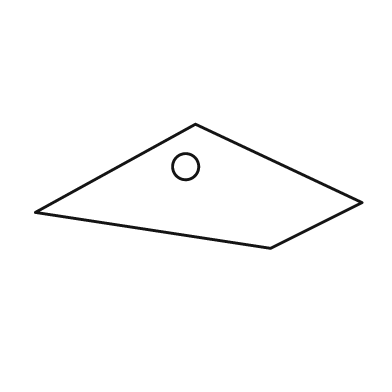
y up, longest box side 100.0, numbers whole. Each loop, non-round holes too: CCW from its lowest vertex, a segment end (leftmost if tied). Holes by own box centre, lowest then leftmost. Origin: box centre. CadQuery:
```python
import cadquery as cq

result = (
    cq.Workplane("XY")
    .moveTo(22.0, -19.0)
    .lineTo(50.0, -5.0)
    .lineTo(-1.0, 19.0)
    .lineTo(-50.0, -8.0)
    .close()
    .moveTo(-4.0, 6.0)
    .circle(4.0)
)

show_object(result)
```